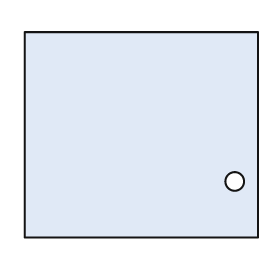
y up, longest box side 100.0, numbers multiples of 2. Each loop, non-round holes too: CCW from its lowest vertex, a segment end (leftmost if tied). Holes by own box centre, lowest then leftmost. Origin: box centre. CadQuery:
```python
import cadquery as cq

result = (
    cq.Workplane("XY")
    .moveTo(-50.0, -44.0)
    .lineTo(50.0, -44.0)
    .lineTo(50.0, 44.0)
    .lineTo(-50.0, 44.0)
    .close()
    .moveTo(40.0, -20.0)
    .circle(4.0)
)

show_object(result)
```